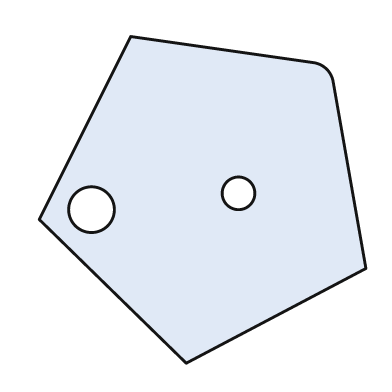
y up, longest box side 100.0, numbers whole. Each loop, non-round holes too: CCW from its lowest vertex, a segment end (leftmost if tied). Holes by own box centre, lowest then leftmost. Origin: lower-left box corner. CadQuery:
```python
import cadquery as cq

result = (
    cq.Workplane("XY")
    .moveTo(45.0, 0.0)
    .lineTo(100.0, 29.0)
    .lineTo(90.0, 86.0)
    .threePointArc((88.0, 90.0), (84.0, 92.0))
    .lineTo(28.0, 100.0)
    .lineTo(0.0, 44.0)
    .close()
    .moveTo(16.0, 47.0)
    .circle(7.0)
    .moveTo(61.0, 52.0)
    .circle(5.0)
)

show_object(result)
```